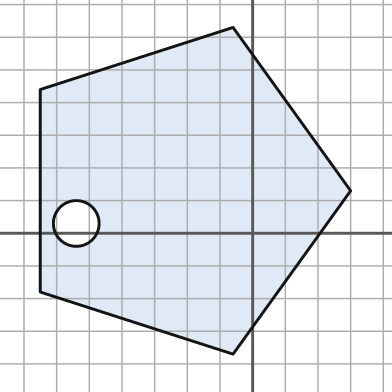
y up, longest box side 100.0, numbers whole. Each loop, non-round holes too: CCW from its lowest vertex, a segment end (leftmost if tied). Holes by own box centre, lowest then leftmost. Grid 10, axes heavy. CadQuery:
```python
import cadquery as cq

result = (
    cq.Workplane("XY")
    .moveTo(-6.0, -37.0)
    .lineTo(30.0, 13.0)
    .lineTo(-6.0, 63.0)
    .lineTo(-65.0, 44.0)
    .lineTo(-65.0, -18.0)
    .close()
    .moveTo(-54.0, 3.0)
    .circle(7.0)
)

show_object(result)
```